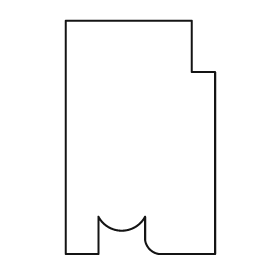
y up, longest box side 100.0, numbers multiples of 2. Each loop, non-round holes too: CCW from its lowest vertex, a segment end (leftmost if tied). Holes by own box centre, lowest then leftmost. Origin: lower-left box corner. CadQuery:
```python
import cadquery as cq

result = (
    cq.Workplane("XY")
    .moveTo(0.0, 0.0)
    .lineTo(14.0, 0.0)
    .lineTo(14.0, 16.0)
    .threePointArc((24.0, 10.0), (34.0, 16.0))
    .lineTo(34.0, 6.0)
    .threePointArc((36.0, 2.0), (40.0, 0.0))
    .lineTo(64.0, 0.0)
    .lineTo(64.0, 78.0)
    .lineTo(54.0, 78.0)
    .lineTo(54.0, 100.0)
    .lineTo(0.0, 100.0)
    .close()
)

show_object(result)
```